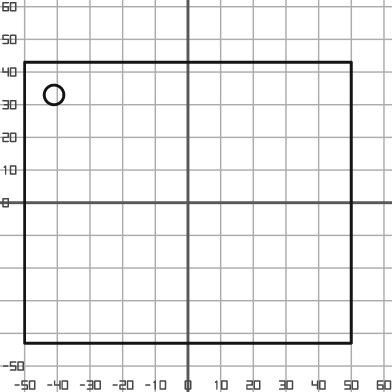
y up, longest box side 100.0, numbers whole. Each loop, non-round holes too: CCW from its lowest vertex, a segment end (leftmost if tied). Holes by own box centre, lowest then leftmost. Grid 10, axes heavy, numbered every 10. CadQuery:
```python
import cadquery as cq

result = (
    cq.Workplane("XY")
    .moveTo(-50.0, -43.0)
    .lineTo(50.0, -43.0)
    .lineTo(50.0, 43.0)
    .lineTo(-50.0, 43.0)
    .close()
    .moveTo(-41.0, 33.0)
    .circle(3.0)
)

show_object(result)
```